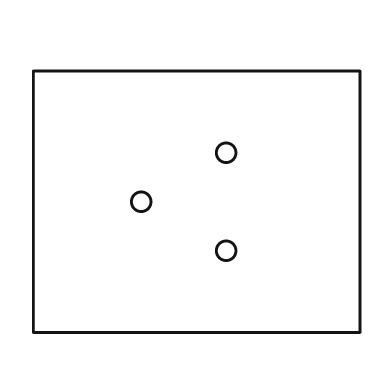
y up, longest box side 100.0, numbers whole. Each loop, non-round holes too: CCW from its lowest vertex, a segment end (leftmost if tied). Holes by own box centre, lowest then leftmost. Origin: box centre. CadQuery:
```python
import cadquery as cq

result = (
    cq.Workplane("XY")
    .moveTo(-50.0, -40.0)
    .lineTo(50.0, -40.0)
    .lineTo(50.0, 40.0)
    .lineTo(-50.0, 40.0)
    .close()
    .moveTo(9.0, -15.0)
    .circle(3.0)
    .moveTo(-17.0, 0.0)
    .circle(3.0)
    .moveTo(9.0, 15.0)
    .circle(3.0)
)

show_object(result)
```